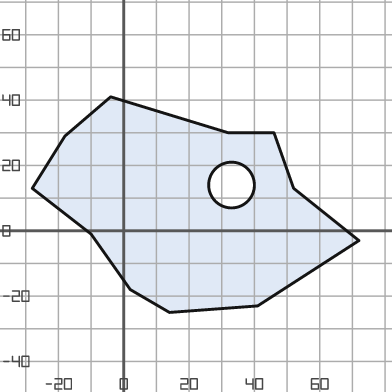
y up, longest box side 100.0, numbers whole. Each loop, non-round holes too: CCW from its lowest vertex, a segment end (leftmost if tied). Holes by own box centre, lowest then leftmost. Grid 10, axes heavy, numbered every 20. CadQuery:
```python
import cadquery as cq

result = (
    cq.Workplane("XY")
    .moveTo(14.0, -25.0)
    .lineTo(41.0, -23.0)
    .lineTo(72.0, -3.0)
    .lineTo(52.0, 13.0)
    .lineTo(46.0, 30.0)
    .lineTo(32.0, 30.0)
    .lineTo(-4.0, 41.0)
    .lineTo(-18.0, 29.0)
    .lineTo(-28.0, 13.0)
    .lineTo(-10.0, -1.0)
    .lineTo(2.0, -18.0)
    .close()
    .moveTo(33.0, 14.0)
    .circle(7.0)
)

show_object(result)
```